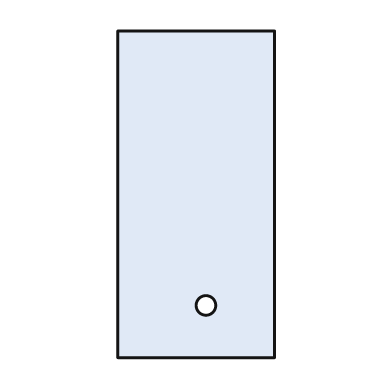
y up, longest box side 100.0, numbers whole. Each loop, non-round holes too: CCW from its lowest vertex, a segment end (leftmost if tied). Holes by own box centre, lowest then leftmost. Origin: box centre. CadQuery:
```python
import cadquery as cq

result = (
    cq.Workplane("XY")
    .moveTo(-24.0, -50.0)
    .lineTo(24.0, -50.0)
    .lineTo(24.0, 50.0)
    .lineTo(-24.0, 50.0)
    .close()
    .moveTo(3.0, -34.0)
    .circle(3.0)
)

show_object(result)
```